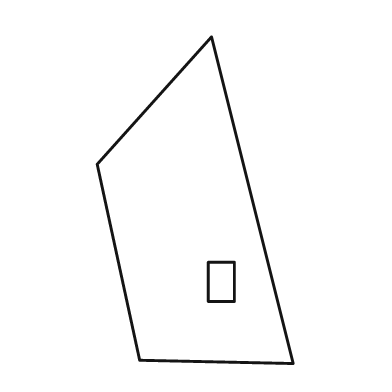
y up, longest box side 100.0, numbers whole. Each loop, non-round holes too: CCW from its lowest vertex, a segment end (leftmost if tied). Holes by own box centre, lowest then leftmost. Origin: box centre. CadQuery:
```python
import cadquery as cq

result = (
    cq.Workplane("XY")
    .moveTo(30.0, -50.0)
    .lineTo(5.0, 50.0)
    .lineTo(-30.0, 11.0)
    .lineTo(-17.0, -49.0)
    .close()
    .moveTo(4.0, -31.0)
    .lineTo(12.0, -31.0)
    .lineTo(12.0, -19.0)
    .lineTo(4.0, -19.0)
    .close()
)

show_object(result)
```